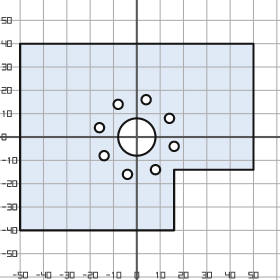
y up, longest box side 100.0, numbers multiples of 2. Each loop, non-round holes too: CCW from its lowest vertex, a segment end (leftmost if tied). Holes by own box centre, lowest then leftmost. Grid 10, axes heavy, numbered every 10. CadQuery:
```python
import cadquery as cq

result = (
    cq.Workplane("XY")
    .moveTo(-50.0, -40.0)
    .lineTo(16.0, -40.0)
    .lineTo(16.0, -14.0)
    .lineTo(50.0, -14.0)
    .lineTo(50.0, 40.0)
    .lineTo(-50.0, 40.0)
    .close()
    .moveTo(-4.0, -16.0)
    .circle(2.0)
    .moveTo(8.0, -14.0)
    .circle(2.0)
    .moveTo(-14.0, -8.0)
    .circle(2.0)
    .moveTo(16.0, -4.0)
    .circle(2.0)
    .moveTo(0.0, 0.0)
    .circle(8.0)
    .moveTo(-16.0, 4.0)
    .circle(2.0)
    .moveTo(14.0, 8.0)
    .circle(2.0)
    .moveTo(-8.0, 14.0)
    .circle(2.0)
    .moveTo(4.0, 16.0)
    .circle(2.0)
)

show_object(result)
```